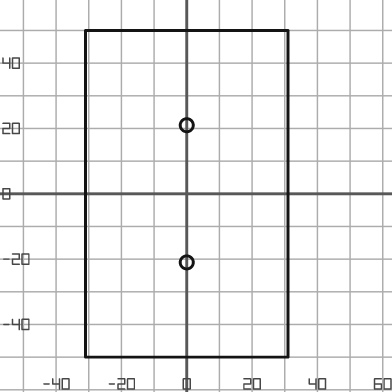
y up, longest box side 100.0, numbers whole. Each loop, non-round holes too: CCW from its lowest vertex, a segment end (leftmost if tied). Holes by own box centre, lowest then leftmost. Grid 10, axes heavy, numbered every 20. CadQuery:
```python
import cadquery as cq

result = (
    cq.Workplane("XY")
    .moveTo(-31.0, -50.0)
    .lineTo(31.0, -50.0)
    .lineTo(31.0, 50.0)
    .lineTo(-31.0, 50.0)
    .close()
    .moveTo(0.0, -21.0)
    .circle(2.0)
    .moveTo(0.0, 21.0)
    .circle(2.0)
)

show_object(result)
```